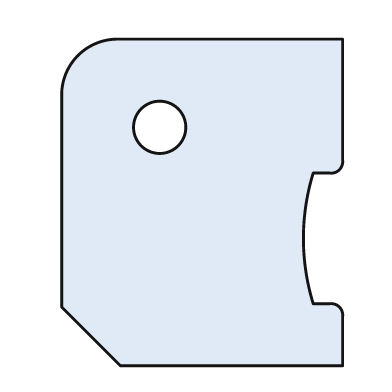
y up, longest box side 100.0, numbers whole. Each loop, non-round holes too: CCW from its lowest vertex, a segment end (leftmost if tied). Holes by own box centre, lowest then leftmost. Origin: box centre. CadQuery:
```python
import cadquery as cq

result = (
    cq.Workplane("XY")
    .moveTo(-25.0, -50.0)
    .lineTo(43.0, -50.0)
    .lineTo(43.0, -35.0)
    .threePointArc((42.0, -32.0), (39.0, -31.0))
    .lineTo(34.0, -31.0)
    .threePointArc((31.0, -11.0), (34.0, 9.0))
    .lineTo(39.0, 9.0)
    .threePointArc((42.0, 10.0), (43.0, 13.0))
    .lineTo(43.0, 50.0)
    .lineTo(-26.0, 50.0)
    .threePointArc((-38.0, 45.0), (-43.0, 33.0))
    .lineTo(-43.0, -32.0)
    .close()
    .moveTo(-13.0, 23.0)
    .circle(8.0)
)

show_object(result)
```